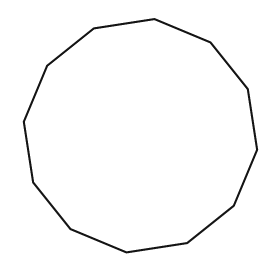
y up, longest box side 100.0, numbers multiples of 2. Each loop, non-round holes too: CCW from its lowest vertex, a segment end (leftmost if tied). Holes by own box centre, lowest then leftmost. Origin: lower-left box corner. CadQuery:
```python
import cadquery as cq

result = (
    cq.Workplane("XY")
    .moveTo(44.0, 0.0)
    .lineTo(70.0, 4.0)
    .lineTo(90.0, 20.0)
    .lineTo(100.0, 44.0)
    .lineTo(96.0, 70.0)
    .lineTo(80.0, 90.0)
    .lineTo(56.0, 100.0)
    .lineTo(30.0, 96.0)
    .lineTo(10.0, 80.0)
    .lineTo(0.0, 56.0)
    .lineTo(4.0, 30.0)
    .lineTo(20.0, 10.0)
    .close()
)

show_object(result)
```